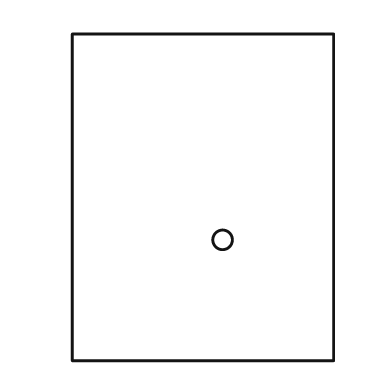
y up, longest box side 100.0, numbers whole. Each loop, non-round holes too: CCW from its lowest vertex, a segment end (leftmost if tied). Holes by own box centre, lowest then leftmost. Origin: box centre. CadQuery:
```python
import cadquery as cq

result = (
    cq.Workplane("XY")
    .moveTo(-40.0, -50.0)
    .lineTo(40.0, -50.0)
    .lineTo(40.0, 50.0)
    .lineTo(-40.0, 50.0)
    .close()
    .moveTo(6.0, -13.0)
    .circle(3.0)
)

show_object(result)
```